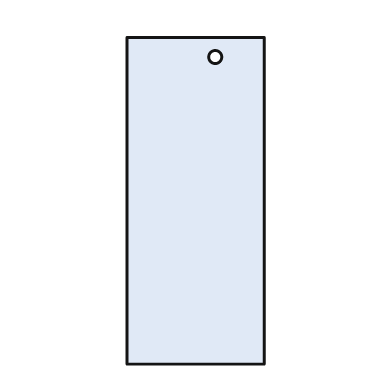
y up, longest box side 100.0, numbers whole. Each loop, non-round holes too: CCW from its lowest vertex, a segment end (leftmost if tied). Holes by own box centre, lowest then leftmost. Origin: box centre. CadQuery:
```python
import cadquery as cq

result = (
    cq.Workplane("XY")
    .moveTo(-21.0, -50.0)
    .lineTo(21.0, -50.0)
    .lineTo(21.0, 50.0)
    .lineTo(-21.0, 50.0)
    .close()
    .moveTo(6.0, 44.0)
    .circle(2.0)
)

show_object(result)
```